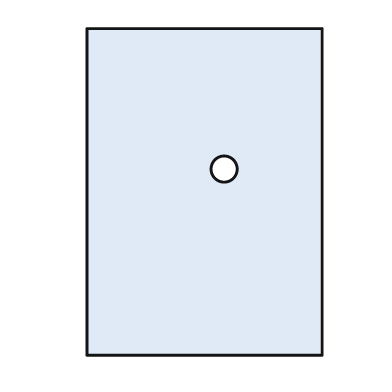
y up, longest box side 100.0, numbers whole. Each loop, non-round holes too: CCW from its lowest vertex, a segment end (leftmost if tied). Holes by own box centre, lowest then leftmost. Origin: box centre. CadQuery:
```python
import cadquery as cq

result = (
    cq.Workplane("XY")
    .moveTo(-36.0, -50.0)
    .lineTo(36.0, -50.0)
    .lineTo(36.0, 50.0)
    .lineTo(-36.0, 50.0)
    .close()
    .moveTo(6.0, 7.0)
    .circle(4.0)
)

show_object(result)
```